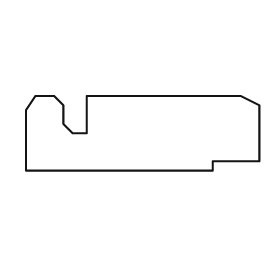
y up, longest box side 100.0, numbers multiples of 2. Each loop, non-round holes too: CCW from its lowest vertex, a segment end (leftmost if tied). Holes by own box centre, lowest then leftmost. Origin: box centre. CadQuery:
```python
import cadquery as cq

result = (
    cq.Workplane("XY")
    .moveTo(-50.0, -16.0)
    .lineTo(30.0, -16.0)
    .lineTo(30.0, -12.0)
    .lineTo(50.0, -12.0)
    .lineTo(50.0, 12.0)
    .lineTo(42.0, 16.0)
    .lineTo(-24.0, 16.0)
    .lineTo(-24.0, 0.0)
    .lineTo(-30.0, 0.0)
    .lineTo(-34.0, 4.0)
    .lineTo(-34.0, 12.0)
    .lineTo(-38.0, 16.0)
    .lineTo(-46.0, 16.0)
    .lineTo(-50.0, 10.0)
    .close()
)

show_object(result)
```